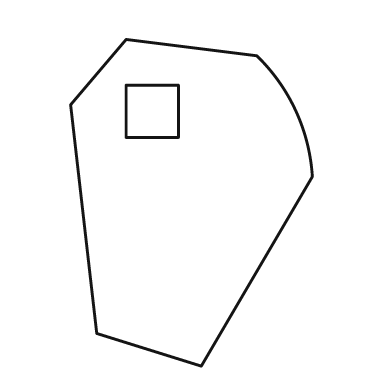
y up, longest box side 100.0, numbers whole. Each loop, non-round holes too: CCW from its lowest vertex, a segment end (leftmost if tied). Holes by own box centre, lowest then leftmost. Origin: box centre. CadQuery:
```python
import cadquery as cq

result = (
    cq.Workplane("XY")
    .moveTo(3.0, -50.0)
    .lineTo(37.0, 8.0)
    .threePointArc((32.0, 28.0), (20.0, 45.0))
    .lineTo(-20.0, 50.0)
    .lineTo(-37.0, 30.0)
    .lineTo(-29.0, -40.0)
    .close()
    .moveTo(-20.0, 20.0)
    .lineTo(-4.0, 20.0)
    .lineTo(-4.0, 36.0)
    .lineTo(-20.0, 36.0)
    .close()
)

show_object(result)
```